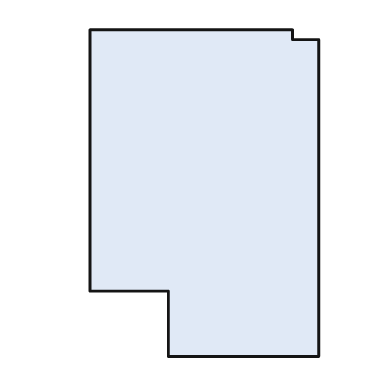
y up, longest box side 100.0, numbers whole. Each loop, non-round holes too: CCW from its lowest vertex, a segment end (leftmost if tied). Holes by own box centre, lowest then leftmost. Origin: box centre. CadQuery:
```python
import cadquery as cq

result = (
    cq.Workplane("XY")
    .moveTo(-11.0, -50.0)
    .lineTo(35.0, -50.0)
    .lineTo(35.0, 47.0)
    .lineTo(27.0, 47.0)
    .lineTo(27.0, 50.0)
    .lineTo(-35.0, 50.0)
    .lineTo(-35.0, -30.0)
    .lineTo(-11.0, -30.0)
    .close()
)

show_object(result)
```